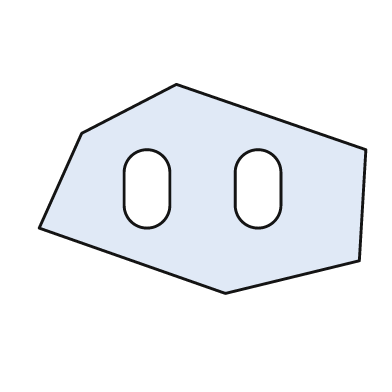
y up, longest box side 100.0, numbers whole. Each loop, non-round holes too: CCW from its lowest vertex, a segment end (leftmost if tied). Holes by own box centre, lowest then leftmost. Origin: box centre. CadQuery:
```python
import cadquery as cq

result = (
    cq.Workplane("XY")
    .moveTo(7.0, -32.0)
    .lineTo(48.0, -22.0)
    .lineTo(50.0, 12.0)
    .lineTo(-8.0, 32.0)
    .lineTo(-37.0, 17.0)
    .lineTo(-50.0, -12.0)
    .close()
    .moveTo(-24.0, -5.0)
    .threePointArc((-17.0, -12.0), (-10.0, -5.0))
    .lineTo(-10.0, 5.0)
    .threePointArc((-17.0, 12.0), (-24.0, 5.0))
    .close()
    .moveTo(10.0, -5.0)
    .threePointArc((17.0, -12.0), (24.0, -5.0))
    .lineTo(24.0, 5.0)
    .threePointArc((17.0, 12.0), (10.0, 5.0))
    .close()
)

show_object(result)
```